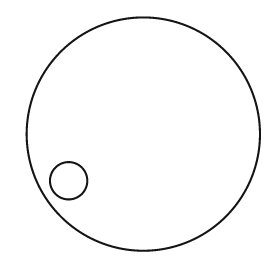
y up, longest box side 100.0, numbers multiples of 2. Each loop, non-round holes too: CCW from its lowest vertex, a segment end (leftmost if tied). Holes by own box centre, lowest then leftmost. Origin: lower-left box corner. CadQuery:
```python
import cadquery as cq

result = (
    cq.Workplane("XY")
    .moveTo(50.0, 50.0)
    .circle(50.0)
    .moveTo(18.0, 30.0)
    .circle(8.0)
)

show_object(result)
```